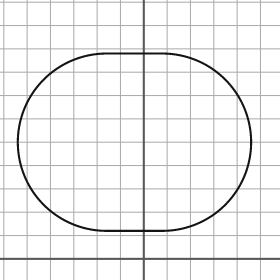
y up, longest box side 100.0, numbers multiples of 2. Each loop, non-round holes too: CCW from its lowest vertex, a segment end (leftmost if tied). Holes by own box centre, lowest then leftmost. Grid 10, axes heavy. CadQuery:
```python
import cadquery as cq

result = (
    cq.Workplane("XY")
    .moveTo(-16.0, 12.0)
    .lineTo(8.0, 12.0)
    .threePointArc((46.0, 50.0), (8.0, 88.0))
    .lineTo(-16.0, 88.0)
    .threePointArc((-54.0, 50.0), (-16.0, 12.0))
    .close()
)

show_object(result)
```